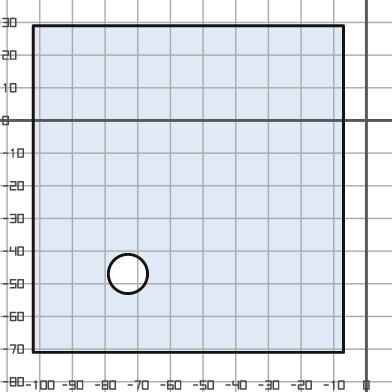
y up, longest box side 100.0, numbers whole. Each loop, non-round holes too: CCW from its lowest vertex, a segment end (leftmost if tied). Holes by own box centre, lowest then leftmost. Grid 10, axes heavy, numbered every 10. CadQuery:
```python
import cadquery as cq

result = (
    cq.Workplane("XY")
    .moveTo(-102.0, -71.0)
    .lineTo(-7.0, -71.0)
    .lineTo(-7.0, 29.0)
    .lineTo(-102.0, 29.0)
    .close()
    .moveTo(-73.0, -47.0)
    .circle(6.0)
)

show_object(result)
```